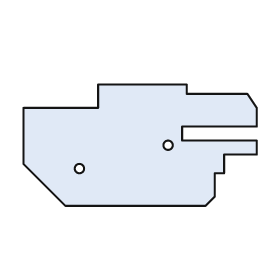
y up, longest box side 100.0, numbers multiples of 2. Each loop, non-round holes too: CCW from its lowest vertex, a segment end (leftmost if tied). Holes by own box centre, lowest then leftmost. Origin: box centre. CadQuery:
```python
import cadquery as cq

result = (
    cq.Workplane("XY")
    .moveTo(-32.0, -26.0)
    .lineTo(28.0, -26.0)
    .lineTo(32.0, -22.0)
    .lineTo(32.0, -12.0)
    .lineTo(36.0, -12.0)
    .lineTo(36.0, -4.0)
    .lineTo(50.0, -4.0)
    .lineTo(50.0, 2.0)
    .lineTo(18.0, 2.0)
    .lineTo(18.0, 8.0)
    .lineTo(50.0, 8.0)
    .lineTo(50.0, 16.0)
    .lineTo(46.0, 22.0)
    .lineTo(20.0, 22.0)
    .lineTo(20.0, 26.0)
    .lineTo(-18.0, 26.0)
    .lineTo(-18.0, 16.0)
    .lineTo(-50.0, 16.0)
    .lineTo(-50.0, -8.0)
    .close()
    .moveTo(-26.0, -10.0)
    .circle(2.0)
    .moveTo(12.0, 0.0)
    .circle(2.0)
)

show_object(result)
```